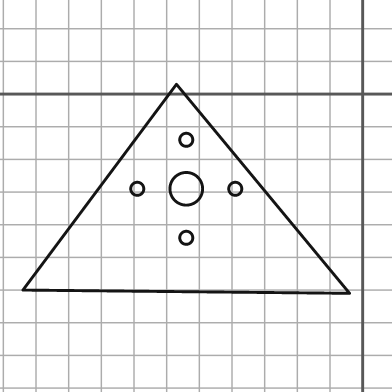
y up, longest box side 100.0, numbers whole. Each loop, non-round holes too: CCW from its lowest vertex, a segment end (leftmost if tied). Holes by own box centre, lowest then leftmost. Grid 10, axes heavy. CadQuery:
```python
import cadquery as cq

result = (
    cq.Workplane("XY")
    .moveTo(-4.0, -61.0)
    .lineTo(-57.0, 3.0)
    .lineTo(-104.0, -60.0)
    .close()
    .moveTo(-54.0, -44.0)
    .circle(2.0)
    .moveTo(-69.0, -29.0)
    .circle(2.0)
    .moveTo(-54.0, -29.0)
    .circle(5.0)
    .moveTo(-39.0, -29.0)
    .circle(2.0)
    .moveTo(-54.0, -14.0)
    .circle(2.0)
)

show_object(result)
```